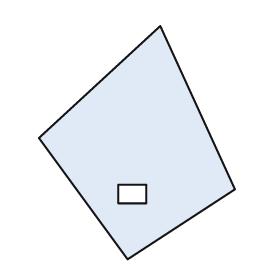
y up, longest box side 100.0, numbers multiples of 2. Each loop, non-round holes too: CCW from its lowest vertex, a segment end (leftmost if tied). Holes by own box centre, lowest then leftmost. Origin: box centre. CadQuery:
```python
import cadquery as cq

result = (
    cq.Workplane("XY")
    .moveTo(-4.0, -50.0)
    .lineTo(42.0, -20.0)
    .lineTo(10.0, 50.0)
    .lineTo(-42.0, 2.0)
    .close()
    .moveTo(-8.0, -26.0)
    .lineTo(4.0, -26.0)
    .lineTo(4.0, -18.0)
    .lineTo(-8.0, -18.0)
    .close()
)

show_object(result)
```